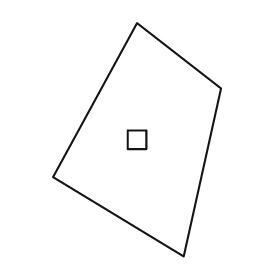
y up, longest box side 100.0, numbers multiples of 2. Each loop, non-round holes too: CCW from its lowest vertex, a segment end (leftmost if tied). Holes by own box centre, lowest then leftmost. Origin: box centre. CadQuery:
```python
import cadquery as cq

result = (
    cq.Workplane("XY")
    .moveTo(20.0, -50.0)
    .lineTo(36.0, 22.0)
    .lineTo(0.0, 50.0)
    .lineTo(-36.0, -16.0)
    .close()
    .moveTo(-4.0, -4.0)
    .lineTo(4.0, -4.0)
    .lineTo(4.0, 4.0)
    .lineTo(-4.0, 4.0)
    .close()
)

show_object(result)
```